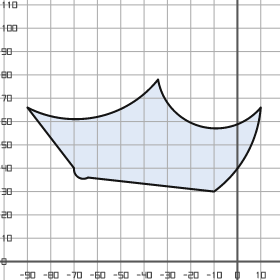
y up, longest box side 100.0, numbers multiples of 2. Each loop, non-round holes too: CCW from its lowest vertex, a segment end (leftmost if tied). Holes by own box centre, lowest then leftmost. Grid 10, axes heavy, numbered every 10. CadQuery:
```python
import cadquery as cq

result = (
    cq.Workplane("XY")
    .moveTo(-10.0, 30.0)
    .threePointArc((4.0, 46.0), (10.0, 66.0))
    .threePointArc((-16.0, 58.0), (-34.0, 78.0))
    .threePointArc((-60.0, 62.0), (-90.0, 66.0))
    .lineTo(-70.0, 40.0)
    .threePointArc((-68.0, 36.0), (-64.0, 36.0))
    .close()
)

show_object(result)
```